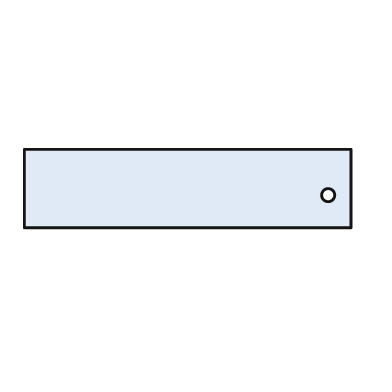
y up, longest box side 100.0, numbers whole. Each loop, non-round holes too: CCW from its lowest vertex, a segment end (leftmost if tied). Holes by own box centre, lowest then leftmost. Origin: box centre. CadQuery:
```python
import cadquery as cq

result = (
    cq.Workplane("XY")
    .moveTo(-50.0, -12.0)
    .lineTo(50.0, -12.0)
    .lineTo(50.0, 12.0)
    .lineTo(-50.0, 12.0)
    .close()
    .moveTo(43.0, -2.0)
    .circle(2.0)
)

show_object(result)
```